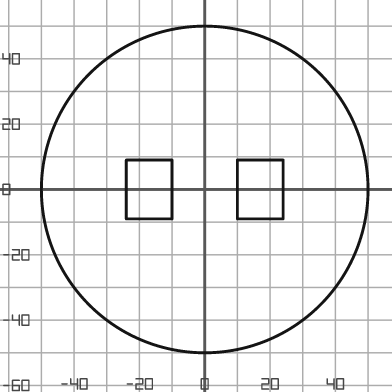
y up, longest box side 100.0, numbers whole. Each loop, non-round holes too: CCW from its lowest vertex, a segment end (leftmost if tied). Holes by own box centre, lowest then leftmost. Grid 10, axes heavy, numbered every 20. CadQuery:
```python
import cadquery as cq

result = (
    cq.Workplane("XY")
    .moveTo(0.0, 0.0)
    .circle(50.0)
    .moveTo(-24.0, -9.0)
    .lineTo(-10.0, -9.0)
    .lineTo(-10.0, 9.0)
    .lineTo(-24.0, 9.0)
    .close()
    .moveTo(10.0, -9.0)
    .lineTo(24.0, -9.0)
    .lineTo(24.0, 9.0)
    .lineTo(10.0, 9.0)
    .close()
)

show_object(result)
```